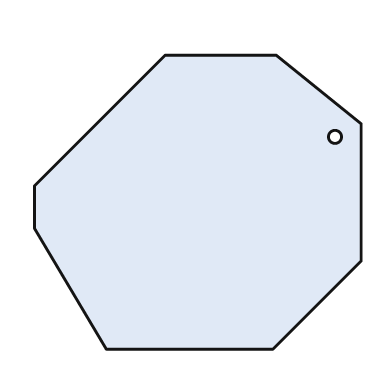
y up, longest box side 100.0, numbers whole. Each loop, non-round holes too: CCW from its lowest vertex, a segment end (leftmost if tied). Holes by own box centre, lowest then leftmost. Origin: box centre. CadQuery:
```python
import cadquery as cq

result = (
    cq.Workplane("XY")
    .moveTo(-28.0, -45.0)
    .lineTo(23.0, -45.0)
    .lineTo(50.0, -18.0)
    .lineTo(50.0, 24.0)
    .lineTo(24.0, 45.0)
    .lineTo(-10.0, 45.0)
    .lineTo(-50.0, 5.0)
    .lineTo(-50.0, -8.0)
    .close()
    .moveTo(42.0, 20.0)
    .circle(2.0)
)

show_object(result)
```